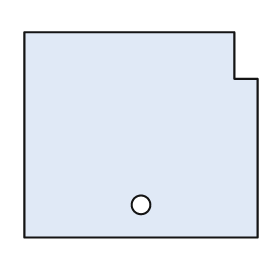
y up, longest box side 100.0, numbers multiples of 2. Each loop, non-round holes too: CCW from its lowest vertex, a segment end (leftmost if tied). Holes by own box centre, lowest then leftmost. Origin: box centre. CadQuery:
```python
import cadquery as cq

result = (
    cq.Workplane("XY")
    .moveTo(-50.0, -44.0)
    .lineTo(50.0, -44.0)
    .lineTo(50.0, 24.0)
    .lineTo(40.0, 24.0)
    .lineTo(40.0, 44.0)
    .lineTo(-50.0, 44.0)
    .close()
    .moveTo(0.0, -30.0)
    .circle(4.0)
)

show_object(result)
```